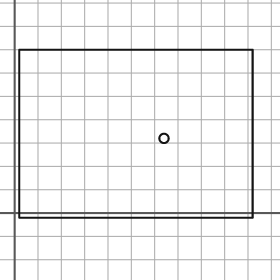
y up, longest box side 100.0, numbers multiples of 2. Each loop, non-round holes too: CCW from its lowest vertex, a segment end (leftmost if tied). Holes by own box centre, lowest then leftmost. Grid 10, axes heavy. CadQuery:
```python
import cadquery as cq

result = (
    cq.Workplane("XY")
    .moveTo(2.0, -2.0)
    .lineTo(102.0, -2.0)
    .lineTo(102.0, 70.0)
    .lineTo(2.0, 70.0)
    .close()
    .moveTo(64.0, 32.0)
    .circle(2.0)
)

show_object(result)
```